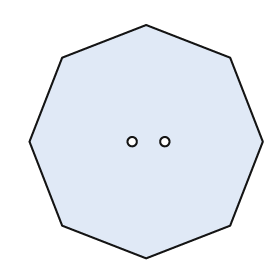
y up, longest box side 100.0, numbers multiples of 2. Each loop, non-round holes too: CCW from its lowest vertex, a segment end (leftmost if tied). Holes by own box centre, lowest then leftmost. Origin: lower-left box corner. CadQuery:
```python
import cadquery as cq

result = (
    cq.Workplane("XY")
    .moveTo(50.0, 0.0)
    .lineTo(86.0, 14.0)
    .lineTo(100.0, 50.0)
    .lineTo(86.0, 86.0)
    .lineTo(50.0, 100.0)
    .lineTo(14.0, 86.0)
    .lineTo(0.0, 50.0)
    .lineTo(14.0, 14.0)
    .close()
    .moveTo(44.0, 50.0)
    .circle(2.0)
    .moveTo(58.0, 50.0)
    .circle(2.0)
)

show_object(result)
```